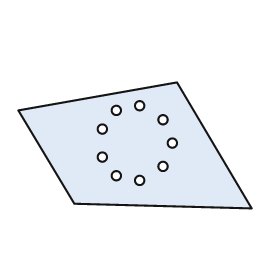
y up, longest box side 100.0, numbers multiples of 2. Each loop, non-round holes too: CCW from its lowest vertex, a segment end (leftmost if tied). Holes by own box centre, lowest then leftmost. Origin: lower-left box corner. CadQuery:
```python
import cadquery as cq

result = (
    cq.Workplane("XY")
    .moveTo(100.0, 0.0)
    .lineTo(68.0, 54.0)
    .lineTo(0.0, 42.0)
    .lineTo(24.0, 2.0)
    .close()
    .moveTo(52.0, 12.0)
    .circle(2.0)
    .moveTo(42.0, 14.0)
    .circle(2.0)
    .moveTo(62.0, 18.0)
    .circle(2.0)
    .moveTo(36.0, 22.0)
    .circle(2.0)
    .moveTo(66.0, 28.0)
    .circle(2.0)
    .moveTo(36.0, 34.0)
    .circle(2.0)
    .moveTo(62.0, 38.0)
    .circle(2.0)
    .moveTo(42.0, 42.0)
    .circle(2.0)
    .moveTo(52.0, 44.0)
    .circle(2.0)
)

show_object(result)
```